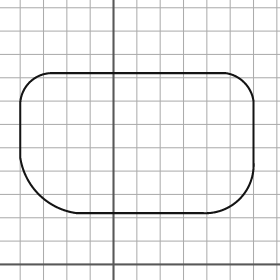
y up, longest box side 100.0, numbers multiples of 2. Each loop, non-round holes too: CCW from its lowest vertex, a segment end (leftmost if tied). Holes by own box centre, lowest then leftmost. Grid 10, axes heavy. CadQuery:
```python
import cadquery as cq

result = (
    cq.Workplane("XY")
    .moveTo(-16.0, 22.0)
    .lineTo(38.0, 22.0)
    .threePointArc((54.0, 28.0), (60.0, 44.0))
    .lineTo(60.0, 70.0)
    .threePointArc((56.0, 78.0), (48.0, 82.0))
    .lineTo(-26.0, 82.0)
    .threePointArc((-36.0, 78.0), (-40.0, 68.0))
    .lineTo(-40.0, 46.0)
    .threePointArc((-32.0, 30.0), (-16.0, 22.0))
    .close()
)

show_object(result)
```